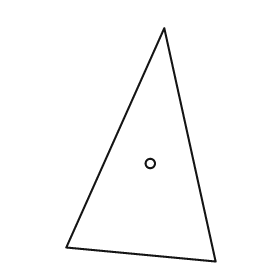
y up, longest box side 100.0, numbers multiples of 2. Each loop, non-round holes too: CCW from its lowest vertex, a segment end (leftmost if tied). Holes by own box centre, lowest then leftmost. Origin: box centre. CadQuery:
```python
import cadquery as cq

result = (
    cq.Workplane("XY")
    .moveTo(32.0, -50.0)
    .lineTo(10.0, 50.0)
    .lineTo(-32.0, -44.0)
    .close()
    .moveTo(4.0, -8.0)
    .circle(2.0)
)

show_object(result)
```